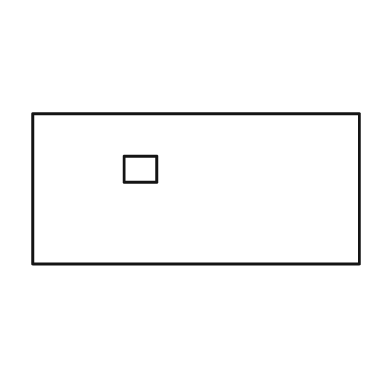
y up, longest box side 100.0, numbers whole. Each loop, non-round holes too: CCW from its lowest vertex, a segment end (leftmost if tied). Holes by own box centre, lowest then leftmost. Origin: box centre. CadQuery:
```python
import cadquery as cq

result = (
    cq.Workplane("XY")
    .moveTo(-50.0, -23.0)
    .lineTo(50.0, -23.0)
    .lineTo(50.0, 23.0)
    .lineTo(-50.0, 23.0)
    .close()
    .moveTo(-22.0, 2.0)
    .lineTo(-12.0, 2.0)
    .lineTo(-12.0, 10.0)
    .lineTo(-22.0, 10.0)
    .close()
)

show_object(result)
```